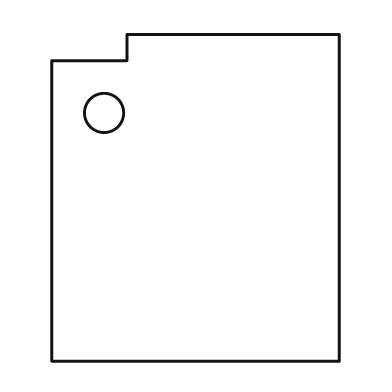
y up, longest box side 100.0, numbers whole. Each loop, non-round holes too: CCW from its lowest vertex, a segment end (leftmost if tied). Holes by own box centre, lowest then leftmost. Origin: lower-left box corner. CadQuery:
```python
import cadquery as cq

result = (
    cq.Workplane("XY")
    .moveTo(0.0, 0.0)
    .lineTo(88.0, 0.0)
    .lineTo(88.0, 100.0)
    .lineTo(23.0, 100.0)
    .lineTo(23.0, 92.0)
    .lineTo(0.0, 92.0)
    .close()
    .moveTo(16.0, 76.0)
    .circle(6.0)
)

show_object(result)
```